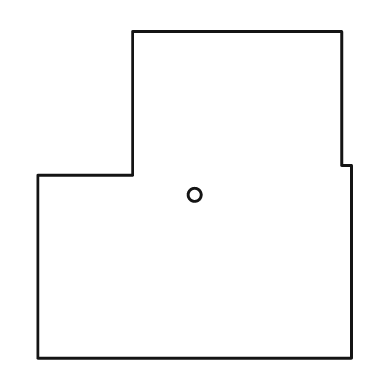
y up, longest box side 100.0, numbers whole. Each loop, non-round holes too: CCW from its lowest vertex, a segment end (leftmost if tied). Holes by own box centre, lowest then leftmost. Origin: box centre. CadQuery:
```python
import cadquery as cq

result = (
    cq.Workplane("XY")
    .moveTo(-48.0, -50.0)
    .lineTo(48.0, -50.0)
    .lineTo(48.0, 9.0)
    .lineTo(45.0, 9.0)
    .lineTo(45.0, 50.0)
    .lineTo(-19.0, 50.0)
    .lineTo(-19.0, 6.0)
    .lineTo(-48.0, 6.0)
    .close()
    .moveTo(0.0, 0.0)
    .circle(2.0)
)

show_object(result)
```